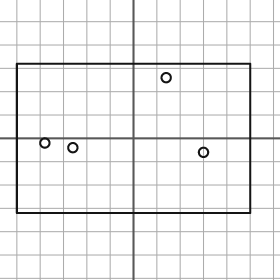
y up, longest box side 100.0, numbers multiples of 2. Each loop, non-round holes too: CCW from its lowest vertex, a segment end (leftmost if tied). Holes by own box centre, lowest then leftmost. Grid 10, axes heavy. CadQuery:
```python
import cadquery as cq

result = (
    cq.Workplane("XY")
    .moveTo(-50.0, -32.0)
    .lineTo(50.0, -32.0)
    .lineTo(50.0, 32.0)
    .lineTo(-50.0, 32.0)
    .close()
    .moveTo(30.0, -6.0)
    .circle(2.0)
    .moveTo(-26.0, -4.0)
    .circle(2.0)
    .moveTo(-38.0, -2.0)
    .circle(2.0)
    .moveTo(14.0, 26.0)
    .circle(2.0)
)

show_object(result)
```